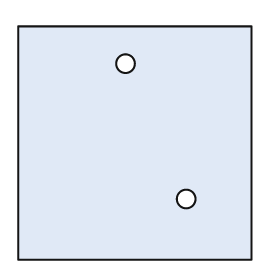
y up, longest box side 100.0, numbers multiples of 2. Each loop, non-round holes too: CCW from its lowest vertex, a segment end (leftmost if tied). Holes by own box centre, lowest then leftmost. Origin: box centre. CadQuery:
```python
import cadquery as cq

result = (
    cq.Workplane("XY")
    .moveTo(-50.0, -50.0)
    .lineTo(50.0, -50.0)
    .lineTo(50.0, 50.0)
    .lineTo(-50.0, 50.0)
    .close()
    .moveTo(22.0, -24.0)
    .circle(4.0)
    .moveTo(-4.0, 34.0)
    .circle(4.0)
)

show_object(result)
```